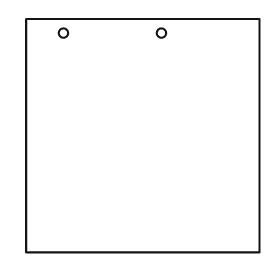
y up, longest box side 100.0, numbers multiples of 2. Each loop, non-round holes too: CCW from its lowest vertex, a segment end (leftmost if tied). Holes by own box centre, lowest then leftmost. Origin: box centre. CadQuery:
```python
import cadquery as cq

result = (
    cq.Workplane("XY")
    .moveTo(-50.0, -50.0)
    .lineTo(50.0, -50.0)
    .lineTo(50.0, 50.0)
    .lineTo(-50.0, 50.0)
    .close()
    .moveTo(-34.0, 44.0)
    .circle(2.0)
    .moveTo(8.0, 44.0)
    .circle(2.0)
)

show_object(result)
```